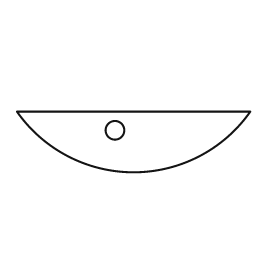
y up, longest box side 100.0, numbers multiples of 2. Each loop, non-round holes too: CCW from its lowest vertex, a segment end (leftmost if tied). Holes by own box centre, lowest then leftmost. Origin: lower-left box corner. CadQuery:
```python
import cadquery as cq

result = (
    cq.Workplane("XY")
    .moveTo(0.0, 26.0)
    .threePointArc((50.0, 0.0), (100.0, 26.0))
    .close()
    .moveTo(42.0, 18.0)
    .circle(4.0)
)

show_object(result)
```